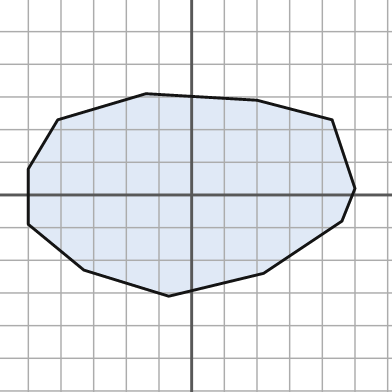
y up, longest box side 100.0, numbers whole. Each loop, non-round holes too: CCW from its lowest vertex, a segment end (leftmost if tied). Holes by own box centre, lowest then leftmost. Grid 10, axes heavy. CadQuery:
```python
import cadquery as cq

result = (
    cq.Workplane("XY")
    .moveTo(-7.0, -31.0)
    .lineTo(22.0, -24.0)
    .lineTo(46.0, -8.0)
    .lineTo(50.0, 2.0)
    .lineTo(43.0, 23.0)
    .lineTo(20.0, 29.0)
    .lineTo(-14.0, 31.0)
    .lineTo(-41.0, 23.0)
    .lineTo(-50.0, 8.0)
    .lineTo(-50.0, -9.0)
    .lineTo(-33.0, -23.0)
    .close()
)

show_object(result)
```